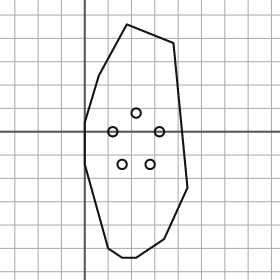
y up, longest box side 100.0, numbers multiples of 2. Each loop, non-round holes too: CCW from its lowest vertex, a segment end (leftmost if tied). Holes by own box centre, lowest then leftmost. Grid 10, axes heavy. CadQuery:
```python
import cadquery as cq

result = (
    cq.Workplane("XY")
    .moveTo(16.0, -54.0)
    .lineTo(22.0, -54.0)
    .lineTo(34.0, -46.0)
    .lineTo(44.0, -24.0)
    .lineTo(38.0, 38.0)
    .lineTo(18.0, 46.0)
    .lineTo(6.0, 24.0)
    .lineTo(0.0, 4.0)
    .lineTo(0.0, -14.0)
    .lineTo(10.0, -50.0)
    .close()
    .moveTo(16.0, -14.0)
    .circle(2.0)
    .moveTo(28.0, -14.0)
    .circle(2.0)
    .moveTo(12.0, 0.0)
    .circle(2.0)
    .moveTo(32.0, 0.0)
    .circle(2.0)
    .moveTo(22.0, 8.0)
    .circle(2.0)
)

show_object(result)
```